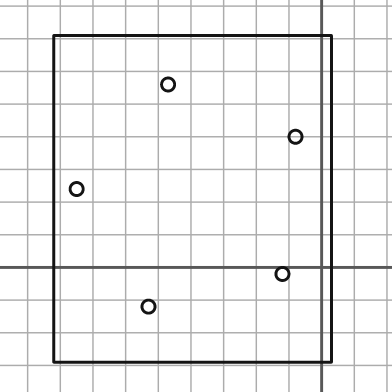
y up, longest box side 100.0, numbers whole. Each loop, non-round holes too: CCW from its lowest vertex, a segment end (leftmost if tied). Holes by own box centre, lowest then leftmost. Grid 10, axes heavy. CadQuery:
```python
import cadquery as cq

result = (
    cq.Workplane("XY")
    .moveTo(-82.0, -29.0)
    .lineTo(3.0, -29.0)
    .lineTo(3.0, 71.0)
    .lineTo(-82.0, 71.0)
    .close()
    .moveTo(-53.0, -12.0)
    .circle(2.0)
    .moveTo(-12.0, -2.0)
    .circle(2.0)
    .moveTo(-75.0, 24.0)
    .circle(2.0)
    .moveTo(-8.0, 40.0)
    .circle(2.0)
    .moveTo(-47.0, 56.0)
    .circle(2.0)
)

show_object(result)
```